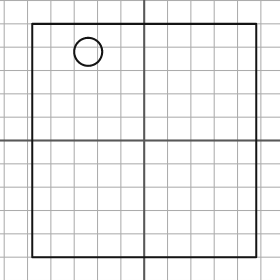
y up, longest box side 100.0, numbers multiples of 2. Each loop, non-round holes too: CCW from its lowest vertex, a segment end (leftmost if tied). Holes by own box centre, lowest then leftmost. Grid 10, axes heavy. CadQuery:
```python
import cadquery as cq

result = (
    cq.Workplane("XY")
    .moveTo(-48.0, -50.0)
    .lineTo(48.0, -50.0)
    .lineTo(48.0, 50.0)
    .lineTo(-48.0, 50.0)
    .close()
    .moveTo(-24.0, 38.0)
    .circle(6.0)
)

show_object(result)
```